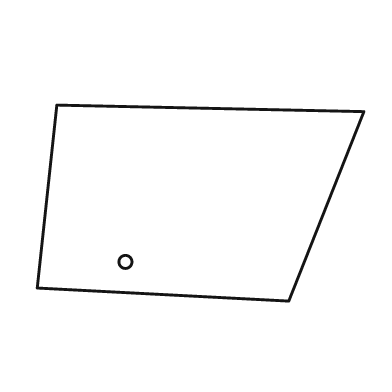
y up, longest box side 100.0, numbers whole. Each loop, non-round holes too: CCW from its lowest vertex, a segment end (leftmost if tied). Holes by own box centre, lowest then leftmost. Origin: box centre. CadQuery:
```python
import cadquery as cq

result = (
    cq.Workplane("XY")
    .moveTo(27.0, -30.0)
    .lineTo(50.0, 28.0)
    .lineTo(-44.0, 30.0)
    .lineTo(-50.0, -26.0)
    .close()
    .moveTo(-23.0, -18.0)
    .circle(2.0)
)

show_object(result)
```